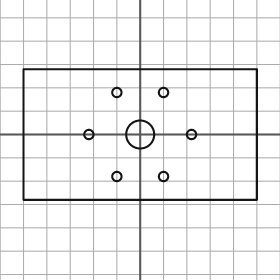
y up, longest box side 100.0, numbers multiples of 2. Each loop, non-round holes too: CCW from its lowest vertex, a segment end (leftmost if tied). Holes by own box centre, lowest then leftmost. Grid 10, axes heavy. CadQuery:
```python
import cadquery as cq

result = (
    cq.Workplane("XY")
    .moveTo(-50.0, -28.0)
    .lineTo(50.0, -28.0)
    .lineTo(50.0, 28.0)
    .lineTo(-50.0, 28.0)
    .close()
    .moveTo(-10.0, -18.0)
    .circle(2.0)
    .moveTo(10.0, -18.0)
    .circle(2.0)
    .moveTo(-22.0, 0.0)
    .circle(2.0)
    .moveTo(0.0, 0.0)
    .circle(6.0)
    .moveTo(22.0, 0.0)
    .circle(2.0)
    .moveTo(-10.0, 18.0)
    .circle(2.0)
    .moveTo(10.0, 18.0)
    .circle(2.0)
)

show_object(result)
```